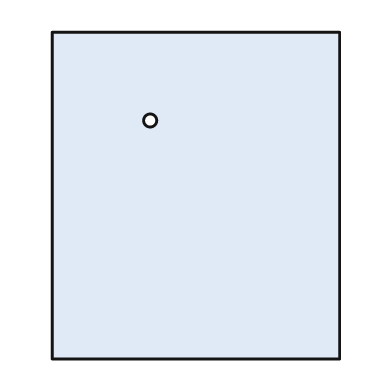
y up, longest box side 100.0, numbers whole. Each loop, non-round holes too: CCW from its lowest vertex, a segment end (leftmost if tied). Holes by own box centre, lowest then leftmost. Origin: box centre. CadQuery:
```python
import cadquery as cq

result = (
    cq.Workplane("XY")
    .moveTo(-44.0, -50.0)
    .lineTo(44.0, -50.0)
    .lineTo(44.0, 50.0)
    .lineTo(-44.0, 50.0)
    .close()
    .moveTo(-14.0, 23.0)
    .circle(2.0)
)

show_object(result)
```